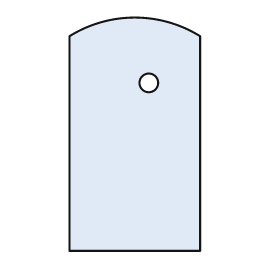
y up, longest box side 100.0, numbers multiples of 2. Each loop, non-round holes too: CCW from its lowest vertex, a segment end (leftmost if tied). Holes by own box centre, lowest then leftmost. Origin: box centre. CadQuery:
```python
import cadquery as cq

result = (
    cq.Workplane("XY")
    .moveTo(-28.0, -50.0)
    .lineTo(28.0, -50.0)
    .lineTo(28.0, 42.0)
    .threePointArc((0.0, 50.0), (-28.0, 42.0))
    .close()
    .moveTo(6.0, 22.0)
    .circle(4.0)
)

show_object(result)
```